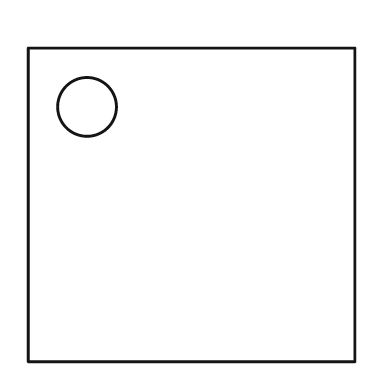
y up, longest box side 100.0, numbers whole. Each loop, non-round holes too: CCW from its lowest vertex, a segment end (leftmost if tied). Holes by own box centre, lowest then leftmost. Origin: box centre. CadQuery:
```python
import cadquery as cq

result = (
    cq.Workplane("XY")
    .moveTo(-50.0, -48.0)
    .lineTo(50.0, -48.0)
    .lineTo(50.0, 48.0)
    .lineTo(-50.0, 48.0)
    .close()
    .moveTo(-32.0, 30.0)
    .circle(9.0)
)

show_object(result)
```